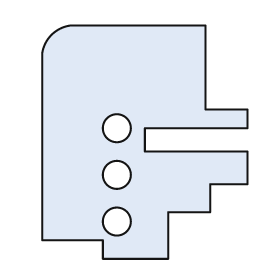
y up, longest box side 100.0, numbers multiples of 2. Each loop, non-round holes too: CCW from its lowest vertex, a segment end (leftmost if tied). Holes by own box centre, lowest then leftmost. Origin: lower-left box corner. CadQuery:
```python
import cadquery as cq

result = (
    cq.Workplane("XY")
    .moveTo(26.0, 0.0)
    .lineTo(54.0, 0.0)
    .lineTo(54.0, 20.0)
    .lineTo(72.0, 20.0)
    .lineTo(72.0, 32.0)
    .lineTo(88.0, 32.0)
    .lineTo(88.0, 46.0)
    .lineTo(44.0, 46.0)
    .lineTo(44.0, 56.0)
    .lineTo(88.0, 56.0)
    .lineTo(88.0, 64.0)
    .lineTo(70.0, 64.0)
    .lineTo(70.0, 100.0)
    .lineTo(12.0, 100.0)
    .threePointArc((4.0, 96.0), (0.0, 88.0))
    .lineTo(0.0, 8.0)
    .lineTo(26.0, 8.0)
    .close()
    .moveTo(32.0, 16.0)
    .circle(6.0)
    .moveTo(32.0, 36.0)
    .circle(6.0)
    .moveTo(32.0, 56.0)
    .circle(6.0)
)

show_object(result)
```